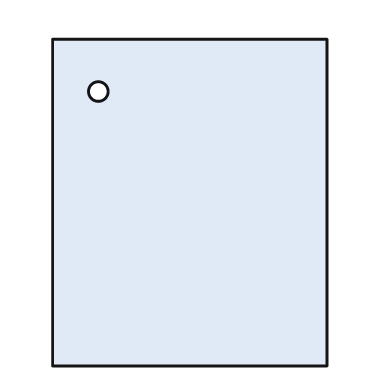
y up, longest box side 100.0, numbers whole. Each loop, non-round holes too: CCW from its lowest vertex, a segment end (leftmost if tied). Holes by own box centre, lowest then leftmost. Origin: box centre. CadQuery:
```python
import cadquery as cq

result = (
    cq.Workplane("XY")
    .moveTo(-42.0, -50.0)
    .lineTo(42.0, -50.0)
    .lineTo(42.0, 50.0)
    .lineTo(-42.0, 50.0)
    .close()
    .moveTo(-28.0, 34.0)
    .circle(3.0)
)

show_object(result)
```